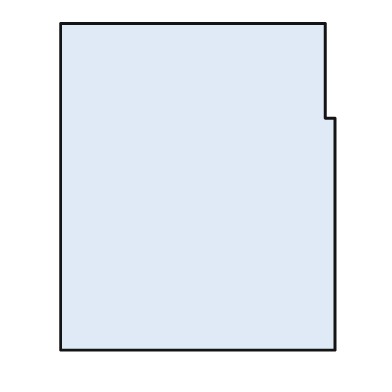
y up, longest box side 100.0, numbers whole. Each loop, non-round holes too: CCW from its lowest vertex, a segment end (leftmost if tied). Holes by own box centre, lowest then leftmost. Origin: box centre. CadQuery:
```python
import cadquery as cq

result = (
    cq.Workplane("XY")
    .moveTo(-42.0, -50.0)
    .lineTo(42.0, -50.0)
    .lineTo(42.0, 21.0)
    .lineTo(39.0, 21.0)
    .lineTo(39.0, 50.0)
    .lineTo(-42.0, 50.0)
    .close()
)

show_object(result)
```